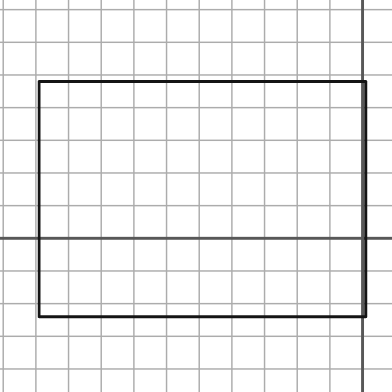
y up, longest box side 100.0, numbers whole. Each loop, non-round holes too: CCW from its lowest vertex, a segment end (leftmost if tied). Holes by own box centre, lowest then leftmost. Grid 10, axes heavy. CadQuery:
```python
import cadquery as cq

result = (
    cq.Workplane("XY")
    .moveTo(-99.0, -24.0)
    .lineTo(1.0, -24.0)
    .lineTo(1.0, 48.0)
    .lineTo(-99.0, 48.0)
    .close()
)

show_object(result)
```